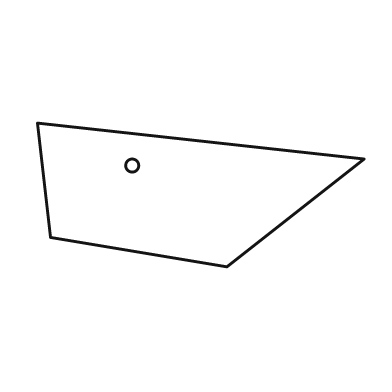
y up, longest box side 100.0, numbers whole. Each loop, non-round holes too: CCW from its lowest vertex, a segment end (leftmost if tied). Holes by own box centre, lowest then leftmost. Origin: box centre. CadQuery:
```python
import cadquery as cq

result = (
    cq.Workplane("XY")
    .moveTo(8.0, -22.0)
    .lineTo(50.0, 11.0)
    .lineTo(-50.0, 22.0)
    .lineTo(-46.0, -13.0)
    .close()
    .moveTo(-21.0, 9.0)
    .circle(2.0)
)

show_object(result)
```